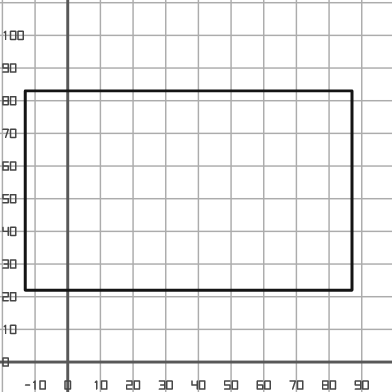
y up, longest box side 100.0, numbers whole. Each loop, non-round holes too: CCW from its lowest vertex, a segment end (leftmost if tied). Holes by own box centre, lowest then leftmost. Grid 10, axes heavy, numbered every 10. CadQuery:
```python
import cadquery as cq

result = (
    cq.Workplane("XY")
    .moveTo(-13.0, 22.0)
    .lineTo(87.0, 22.0)
    .lineTo(87.0, 83.0)
    .lineTo(-13.0, 83.0)
    .close()
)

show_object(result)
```